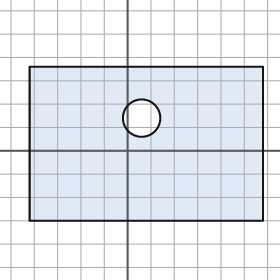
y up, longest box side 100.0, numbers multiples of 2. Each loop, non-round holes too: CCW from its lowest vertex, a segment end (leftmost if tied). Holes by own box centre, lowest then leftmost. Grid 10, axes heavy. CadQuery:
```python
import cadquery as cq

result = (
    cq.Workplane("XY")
    .moveTo(-42.0, -30.0)
    .lineTo(58.0, -30.0)
    .lineTo(58.0, 36.0)
    .lineTo(-42.0, 36.0)
    .close()
    .moveTo(6.0, 14.0)
    .circle(8.0)
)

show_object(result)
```